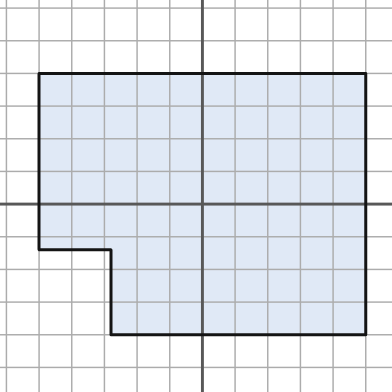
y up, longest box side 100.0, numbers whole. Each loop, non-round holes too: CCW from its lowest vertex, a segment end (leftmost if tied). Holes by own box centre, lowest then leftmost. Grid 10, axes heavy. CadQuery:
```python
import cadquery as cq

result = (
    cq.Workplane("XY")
    .moveTo(-28.0, -40.0)
    .lineTo(50.0, -40.0)
    .lineTo(50.0, 40.0)
    .lineTo(-50.0, 40.0)
    .lineTo(-50.0, -14.0)
    .lineTo(-28.0, -14.0)
    .close()
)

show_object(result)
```